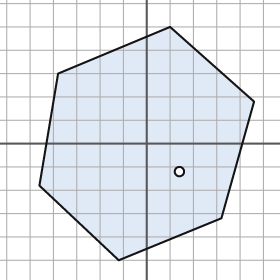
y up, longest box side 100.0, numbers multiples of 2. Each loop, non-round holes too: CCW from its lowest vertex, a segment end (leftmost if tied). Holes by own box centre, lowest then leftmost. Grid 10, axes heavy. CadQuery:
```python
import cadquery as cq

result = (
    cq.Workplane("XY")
    .moveTo(-12.0, -50.0)
    .lineTo(32.0, -32.0)
    .lineTo(46.0, 18.0)
    .lineTo(10.0, 50.0)
    .lineTo(-38.0, 30.0)
    .lineTo(-46.0, -18.0)
    .close()
    .moveTo(14.0, -12.0)
    .circle(2.0)
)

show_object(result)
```